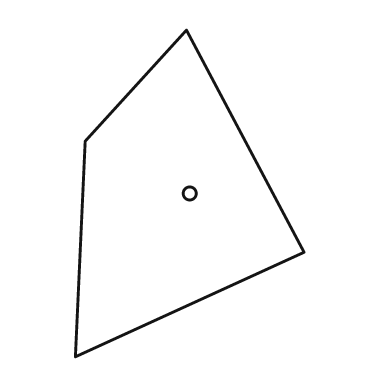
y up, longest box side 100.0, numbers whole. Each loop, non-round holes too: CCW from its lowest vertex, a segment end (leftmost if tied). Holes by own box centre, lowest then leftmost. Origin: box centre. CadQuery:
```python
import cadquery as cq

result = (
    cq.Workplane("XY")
    .moveTo(-35.0, -50.0)
    .lineTo(35.0, -18.0)
    .lineTo(-1.0, 50.0)
    .lineTo(-32.0, 16.0)
    .close()
    .moveTo(0.0, 0.0)
    .circle(2.0)
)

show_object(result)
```